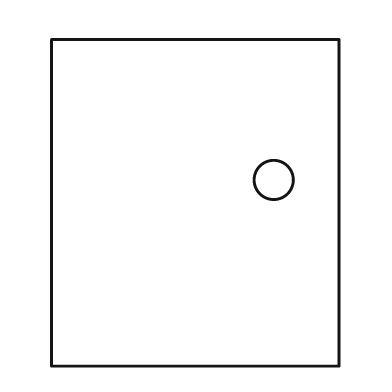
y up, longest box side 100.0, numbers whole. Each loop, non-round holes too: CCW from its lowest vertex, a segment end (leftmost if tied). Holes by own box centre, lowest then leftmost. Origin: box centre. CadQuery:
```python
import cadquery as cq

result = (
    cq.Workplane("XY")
    .moveTo(-44.0, -50.0)
    .lineTo(44.0, -50.0)
    .lineTo(44.0, 50.0)
    .lineTo(-44.0, 50.0)
    .close()
    .moveTo(24.0, 7.0)
    .circle(6.0)
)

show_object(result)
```